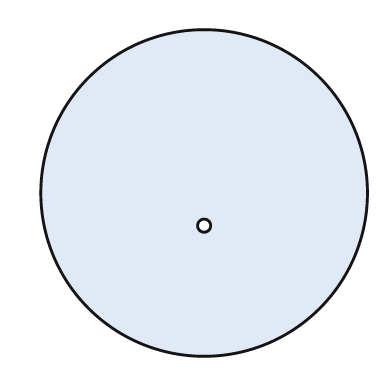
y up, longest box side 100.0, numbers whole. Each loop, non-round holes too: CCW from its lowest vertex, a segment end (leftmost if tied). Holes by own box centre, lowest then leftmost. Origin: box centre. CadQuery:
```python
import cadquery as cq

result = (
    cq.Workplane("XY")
    .moveTo(0.0, 0.0)
    .circle(50.0)
    .moveTo(0.0, -10.0)
    .circle(2.0)
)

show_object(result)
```